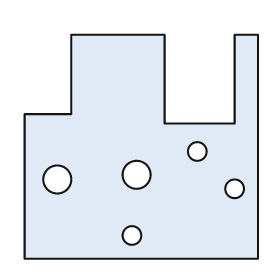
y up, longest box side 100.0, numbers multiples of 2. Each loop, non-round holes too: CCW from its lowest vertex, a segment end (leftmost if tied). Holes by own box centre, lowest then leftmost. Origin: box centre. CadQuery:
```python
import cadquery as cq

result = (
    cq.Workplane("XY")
    .moveTo(-50.0, -48.0)
    .lineTo(50.0, -48.0)
    .lineTo(50.0, 48.0)
    .lineTo(40.0, 48.0)
    .lineTo(40.0, 10.0)
    .lineTo(10.0, 10.0)
    .lineTo(10.0, 48.0)
    .lineTo(-30.0, 48.0)
    .lineTo(-30.0, 14.0)
    .lineTo(-50.0, 14.0)
    .close()
    .moveTo(-4.0, -38.0)
    .circle(4.0)
    .moveTo(40.0, -18.0)
    .circle(4.0)
    .moveTo(-36.0, -14.0)
    .circle(6.0)
    .moveTo(-2.0, -12.0)
    .circle(6.0)
    .moveTo(24.0, -2.0)
    .circle(4.0)
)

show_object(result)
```